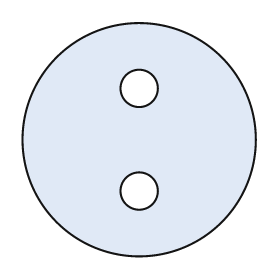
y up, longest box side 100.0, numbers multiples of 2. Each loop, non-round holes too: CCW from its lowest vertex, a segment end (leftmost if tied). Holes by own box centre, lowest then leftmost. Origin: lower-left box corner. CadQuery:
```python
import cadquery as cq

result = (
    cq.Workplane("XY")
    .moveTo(50.0, 50.0)
    .circle(50.0)
    .moveTo(50.0, 28.0)
    .circle(8.0)
    .moveTo(50.0, 72.0)
    .circle(8.0)
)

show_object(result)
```